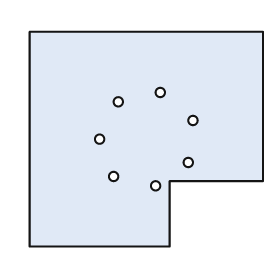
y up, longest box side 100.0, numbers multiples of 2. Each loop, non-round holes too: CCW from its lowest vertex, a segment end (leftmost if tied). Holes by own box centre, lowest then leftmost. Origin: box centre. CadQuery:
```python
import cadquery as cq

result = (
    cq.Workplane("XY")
    .moveTo(-50.0, -46.0)
    .lineTo(10.0, -46.0)
    .lineTo(10.0, -18.0)
    .lineTo(50.0, -18.0)
    .lineTo(50.0, 46.0)
    .lineTo(-50.0, 46.0)
    .close()
    .moveTo(4.0, -20.0)
    .circle(2.0)
    .moveTo(-14.0, -16.0)
    .circle(2.0)
    .moveTo(18.0, -10.0)
    .circle(2.0)
    .moveTo(-20.0, 0.0)
    .circle(2.0)
    .moveTo(20.0, 8.0)
    .circle(2.0)
    .moveTo(-12.0, 16.0)
    .circle(2.0)
    .moveTo(6.0, 20.0)
    .circle(2.0)
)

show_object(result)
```